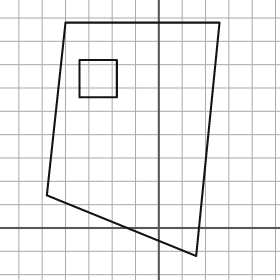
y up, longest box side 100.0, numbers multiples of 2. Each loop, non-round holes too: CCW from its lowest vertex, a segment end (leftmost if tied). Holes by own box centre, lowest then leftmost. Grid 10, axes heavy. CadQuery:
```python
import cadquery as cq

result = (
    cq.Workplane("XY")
    .moveTo(16.0, -12.0)
    .lineTo(26.0, 88.0)
    .lineTo(-40.0, 88.0)
    .lineTo(-48.0, 14.0)
    .close()
    .moveTo(-34.0, 56.0)
    .lineTo(-18.0, 56.0)
    .lineTo(-18.0, 72.0)
    .lineTo(-34.0, 72.0)
    .close()
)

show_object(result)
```